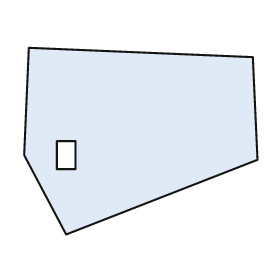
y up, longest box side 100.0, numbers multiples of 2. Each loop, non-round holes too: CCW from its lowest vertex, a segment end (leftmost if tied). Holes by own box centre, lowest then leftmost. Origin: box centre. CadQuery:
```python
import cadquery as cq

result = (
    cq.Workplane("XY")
    .moveTo(-32.0, -40.0)
    .lineTo(50.0, -8.0)
    .lineTo(48.0, 36.0)
    .lineTo(-48.0, 40.0)
    .lineTo(-50.0, -6.0)
    .close()
    .moveTo(-36.0, -12.0)
    .lineTo(-28.0, -12.0)
    .lineTo(-28.0, 0.0)
    .lineTo(-36.0, 0.0)
    .close()
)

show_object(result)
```